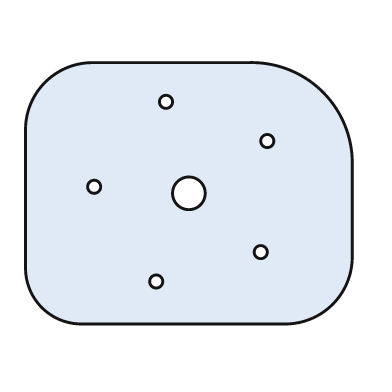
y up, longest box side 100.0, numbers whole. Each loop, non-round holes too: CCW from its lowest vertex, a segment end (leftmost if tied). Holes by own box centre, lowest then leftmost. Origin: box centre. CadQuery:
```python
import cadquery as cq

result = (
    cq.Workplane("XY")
    .moveTo(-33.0, -40.0)
    .lineTo(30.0, -40.0)
    .threePointArc((44.0, -34.0), (50.0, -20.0))
    .lineTo(50.0, 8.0)
    .threePointArc((41.0, 31.0), (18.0, 40.0))
    .lineTo(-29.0, 40.0)
    .threePointArc((-44.0, 34.0), (-50.0, 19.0))
    .lineTo(-50.0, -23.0)
    .threePointArc((-45.0, -35.0), (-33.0, -40.0))
    .close()
    .moveTo(-10.0, -27.0)
    .circle(2.0)
    .moveTo(22.0, -18.0)
    .circle(2.0)
    .moveTo(0.0, 0.0)
    .circle(5.0)
    .moveTo(-29.0, 2.0)
    .circle(2.0)
    .moveTo(24.0, 16.0)
    .circle(2.0)
    .moveTo(-7.0, 28.0)
    .circle(2.0)
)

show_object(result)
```